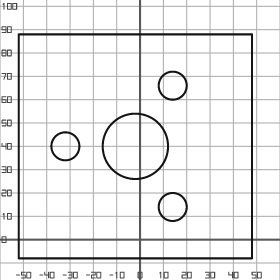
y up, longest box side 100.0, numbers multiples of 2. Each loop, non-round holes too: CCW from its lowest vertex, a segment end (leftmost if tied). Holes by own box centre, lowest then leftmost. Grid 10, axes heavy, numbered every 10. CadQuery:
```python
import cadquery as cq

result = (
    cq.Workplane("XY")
    .moveTo(-52.0, -8.0)
    .lineTo(48.0, -8.0)
    .lineTo(48.0, 88.0)
    .lineTo(-52.0, 88.0)
    .close()
    .moveTo(14.0, 14.0)
    .circle(6.0)
    .moveTo(-32.0, 40.0)
    .circle(6.0)
    .moveTo(-2.0, 40.0)
    .circle(14.0)
    .moveTo(14.0, 66.0)
    .circle(6.0)
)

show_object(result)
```